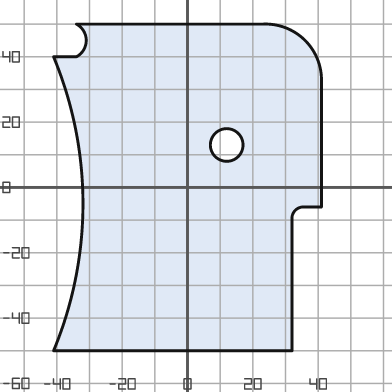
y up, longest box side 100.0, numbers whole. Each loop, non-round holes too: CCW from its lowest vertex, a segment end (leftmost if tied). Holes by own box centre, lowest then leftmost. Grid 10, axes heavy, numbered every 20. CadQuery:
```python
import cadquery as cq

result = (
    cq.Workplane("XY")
    .moveTo(-41.0, -50.0)
    .lineTo(32.0, -50.0)
    .lineTo(32.0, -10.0)
    .threePointArc((33.0, -7.0), (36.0, -6.0))
    .lineTo(41.0, -6.0)
    .lineTo(41.0, 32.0)
    .threePointArc((36.0, 45.0), (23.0, 50.0))
    .lineTo(-34.0, 50.0)
    .threePointArc((-31.0, 45.0), (-34.0, 40.0))
    .lineTo(-41.0, 40.0)
    .threePointArc((-32.0, -5.0), (-41.0, -50.0))
    .close()
    .moveTo(12.0, 13.0)
    .circle(5.0)
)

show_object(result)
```